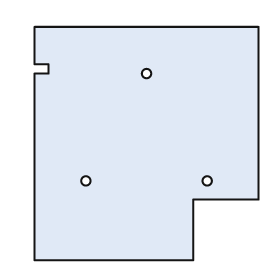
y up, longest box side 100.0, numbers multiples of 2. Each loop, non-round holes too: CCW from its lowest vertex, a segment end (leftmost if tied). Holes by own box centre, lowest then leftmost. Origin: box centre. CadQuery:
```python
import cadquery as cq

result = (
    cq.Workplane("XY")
    .moveTo(-48.0, -50.0)
    .lineTo(20.0, -50.0)
    .lineTo(20.0, -24.0)
    .lineTo(48.0, -24.0)
    .lineTo(48.0, 50.0)
    .lineTo(-48.0, 50.0)
    .lineTo(-48.0, 34.0)
    .lineTo(-42.0, 34.0)
    .lineTo(-42.0, 30.0)
    .lineTo(-48.0, 30.0)
    .close()
    .moveTo(-26.0, -16.0)
    .circle(2.0)
    .moveTo(26.0, -16.0)
    .circle(2.0)
    .moveTo(0.0, 30.0)
    .circle(2.0)
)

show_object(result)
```